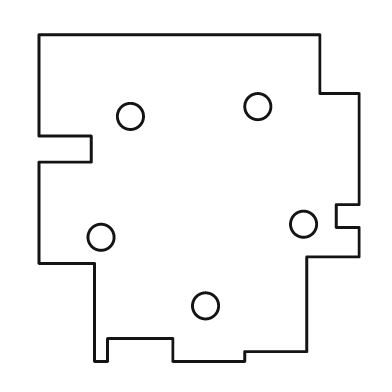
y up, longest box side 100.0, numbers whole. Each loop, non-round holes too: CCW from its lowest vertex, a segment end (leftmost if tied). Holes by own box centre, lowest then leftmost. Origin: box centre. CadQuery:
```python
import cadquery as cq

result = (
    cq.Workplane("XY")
    .moveTo(-32.0, -50.0)
    .lineTo(-28.0, -50.0)
    .lineTo(-28.0, -43.0)
    .lineTo(-8.0, -43.0)
    .lineTo(-8.0, -50.0)
    .lineTo(14.0, -50.0)
    .lineTo(14.0, -47.0)
    .lineTo(33.0, -47.0)
    .lineTo(33.0, -18.0)
    .lineTo(49.0, -18.0)
    .lineTo(49.0, -9.0)
    .lineTo(42.0, -9.0)
    .lineTo(42.0, -2.0)
    .lineTo(49.0, -2.0)
    .lineTo(49.0, 32.0)
    .lineTo(37.0, 32.0)
    .lineTo(37.0, 50.0)
    .lineTo(-49.0, 50.0)
    .lineTo(-49.0, 19.0)
    .lineTo(-33.0, 19.0)
    .lineTo(-33.0, 11.0)
    .lineTo(-49.0, 11.0)
    .lineTo(-49.0, -20.0)
    .lineTo(-32.0, -20.0)
    .close()
    .moveTo(2.0, -33.0)
    .circle(4.0)
    .moveTo(-30.0, -12.0)
    .circle(4.0)
    .moveTo(32.0, -8.0)
    .circle(4.0)
    .moveTo(-21.0, 25.0)
    .circle(4.0)
    .moveTo(18.0, 28.0)
    .circle(4.0)
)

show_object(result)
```